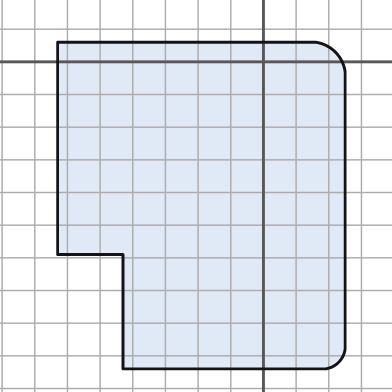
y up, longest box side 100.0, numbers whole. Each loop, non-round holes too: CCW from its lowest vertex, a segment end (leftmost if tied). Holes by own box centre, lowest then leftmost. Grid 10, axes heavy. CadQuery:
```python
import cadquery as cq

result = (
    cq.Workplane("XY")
    .moveTo(-43.0, -94.0)
    .lineTo(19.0, -94.0)
    .threePointArc((23.0, -92.0), (25.0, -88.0))
    .lineTo(25.0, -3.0)
    .threePointArc((22.0, 3.0), (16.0, 6.0))
    .lineTo(-63.0, 6.0)
    .lineTo(-63.0, -59.0)
    .lineTo(-43.0, -59.0)
    .close()
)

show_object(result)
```